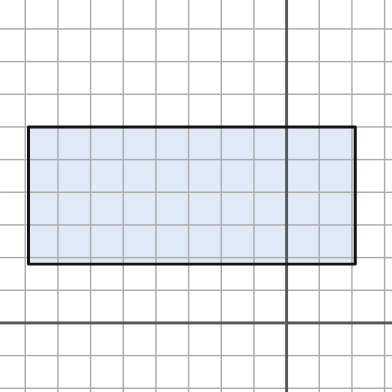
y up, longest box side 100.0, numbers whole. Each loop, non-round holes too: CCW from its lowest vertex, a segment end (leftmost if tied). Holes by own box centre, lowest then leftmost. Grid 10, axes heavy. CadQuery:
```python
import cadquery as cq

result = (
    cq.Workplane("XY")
    .moveTo(-79.0, 18.0)
    .lineTo(21.0, 18.0)
    .lineTo(21.0, 60.0)
    .lineTo(-79.0, 60.0)
    .close()
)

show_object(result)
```